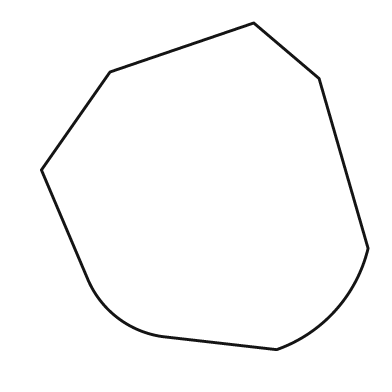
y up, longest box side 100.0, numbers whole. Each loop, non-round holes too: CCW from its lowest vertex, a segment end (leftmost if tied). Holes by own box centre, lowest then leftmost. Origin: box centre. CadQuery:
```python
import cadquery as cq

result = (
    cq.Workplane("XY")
    .moveTo(22.0, -50.0)
    .threePointArc((40.0, -38.0), (50.0, -19.0))
    .lineTo(35.0, 33.0)
    .lineTo(15.0, 50.0)
    .lineTo(-29.0, 35.0)
    .lineTo(-50.0, 5.0)
    .lineTo(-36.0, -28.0)
    .threePointArc((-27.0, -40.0), (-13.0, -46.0))
    .close()
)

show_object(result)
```